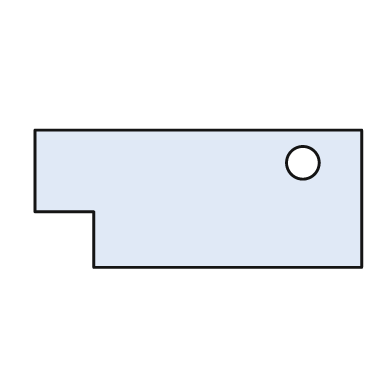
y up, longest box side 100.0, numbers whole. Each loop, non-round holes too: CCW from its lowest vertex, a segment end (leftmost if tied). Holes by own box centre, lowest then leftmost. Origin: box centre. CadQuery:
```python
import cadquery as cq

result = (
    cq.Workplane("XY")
    .moveTo(-32.0, -21.0)
    .lineTo(50.0, -21.0)
    .lineTo(50.0, 21.0)
    .lineTo(-50.0, 21.0)
    .lineTo(-50.0, -4.0)
    .lineTo(-32.0, -4.0)
    .close()
    .moveTo(32.0, 11.0)
    .circle(5.0)
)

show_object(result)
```